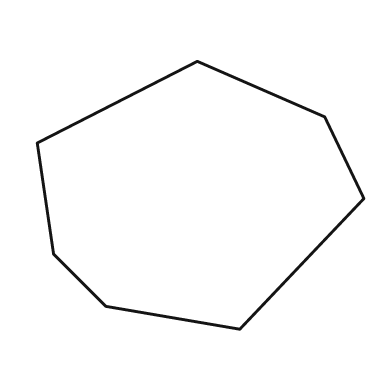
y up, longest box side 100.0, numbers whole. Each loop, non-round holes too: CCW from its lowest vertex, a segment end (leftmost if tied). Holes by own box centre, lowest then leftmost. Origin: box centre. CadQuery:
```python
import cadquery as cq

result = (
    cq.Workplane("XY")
    .moveTo(12.0, -41.0)
    .lineTo(50.0, -1.0)
    .lineTo(38.0, 24.0)
    .lineTo(-1.0, 41.0)
    .lineTo(-50.0, 16.0)
    .lineTo(-45.0, -18.0)
    .lineTo(-29.0, -34.0)
    .close()
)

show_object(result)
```